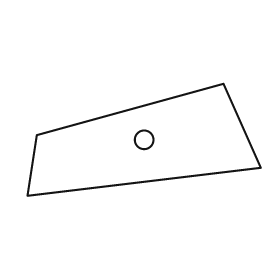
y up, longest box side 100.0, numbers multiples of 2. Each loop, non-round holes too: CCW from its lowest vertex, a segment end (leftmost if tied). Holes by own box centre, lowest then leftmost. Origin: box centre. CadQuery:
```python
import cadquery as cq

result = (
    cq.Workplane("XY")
    .moveTo(-50.0, -24.0)
    .lineTo(50.0, -12.0)
    .lineTo(34.0, 24.0)
    .lineTo(-46.0, 2.0)
    .close()
    .moveTo(0.0, 0.0)
    .circle(4.0)
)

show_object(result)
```